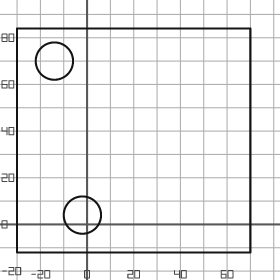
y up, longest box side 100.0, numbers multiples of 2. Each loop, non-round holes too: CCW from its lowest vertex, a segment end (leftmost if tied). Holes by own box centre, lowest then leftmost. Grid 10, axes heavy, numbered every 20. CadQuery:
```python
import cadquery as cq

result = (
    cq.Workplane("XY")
    .moveTo(-30.0, -12.0)
    .lineTo(70.0, -12.0)
    .lineTo(70.0, 84.0)
    .lineTo(-30.0, 84.0)
    .close()
    .moveTo(-2.0, 4.0)
    .circle(8.0)
    .moveTo(-14.0, 70.0)
    .circle(8.0)
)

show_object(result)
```